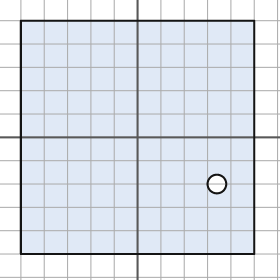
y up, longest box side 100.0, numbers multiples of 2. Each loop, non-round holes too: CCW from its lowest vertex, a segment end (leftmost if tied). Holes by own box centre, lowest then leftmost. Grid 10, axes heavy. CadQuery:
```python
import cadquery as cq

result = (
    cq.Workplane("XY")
    .moveTo(-50.0, -50.0)
    .lineTo(50.0, -50.0)
    .lineTo(50.0, 50.0)
    .lineTo(-50.0, 50.0)
    .close()
    .moveTo(34.0, -20.0)
    .circle(4.0)
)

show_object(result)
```